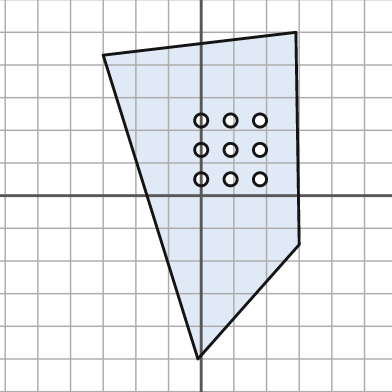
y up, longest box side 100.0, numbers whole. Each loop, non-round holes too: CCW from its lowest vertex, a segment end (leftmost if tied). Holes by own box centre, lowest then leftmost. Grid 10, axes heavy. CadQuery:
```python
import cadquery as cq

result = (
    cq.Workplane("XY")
    .moveTo(-1.0, -50.0)
    .lineTo(30.0, -15.0)
    .lineTo(29.0, 50.0)
    .lineTo(-30.0, 43.0)
    .close()
    .moveTo(0.0, 5.0)
    .circle(2.0)
    .moveTo(9.0, 5.0)
    .circle(2.0)
    .moveTo(18.0, 5.0)
    .circle(2.0)
    .moveTo(0.0, 14.0)
    .circle(2.0)
    .moveTo(9.0, 14.0)
    .circle(2.0)
    .moveTo(18.0, 14.0)
    .circle(2.0)
    .moveTo(0.0, 23.0)
    .circle(2.0)
    .moveTo(9.0, 23.0)
    .circle(2.0)
    .moveTo(18.0, 23.0)
    .circle(2.0)
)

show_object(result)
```